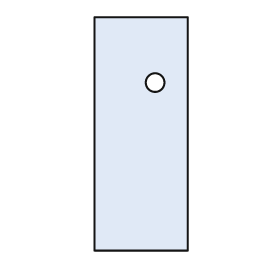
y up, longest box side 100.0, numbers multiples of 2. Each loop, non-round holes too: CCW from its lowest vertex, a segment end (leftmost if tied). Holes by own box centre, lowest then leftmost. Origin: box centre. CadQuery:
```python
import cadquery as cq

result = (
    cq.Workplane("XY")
    .moveTo(-20.0, -50.0)
    .lineTo(20.0, -50.0)
    .lineTo(20.0, 50.0)
    .lineTo(-20.0, 50.0)
    .close()
    .moveTo(6.0, 22.0)
    .circle(4.0)
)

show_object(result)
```